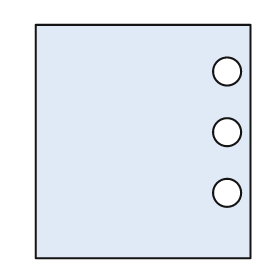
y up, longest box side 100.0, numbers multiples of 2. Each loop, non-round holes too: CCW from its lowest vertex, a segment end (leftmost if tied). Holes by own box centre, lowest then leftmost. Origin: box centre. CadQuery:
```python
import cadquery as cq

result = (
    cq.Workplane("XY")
    .moveTo(-46.0, -50.0)
    .lineTo(46.0, -50.0)
    .lineTo(46.0, 50.0)
    .lineTo(-46.0, 50.0)
    .close()
    .moveTo(36.0, -22.0)
    .circle(6.0)
    .moveTo(36.0, 4.0)
    .circle(6.0)
    .moveTo(36.0, 30.0)
    .circle(6.0)
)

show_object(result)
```